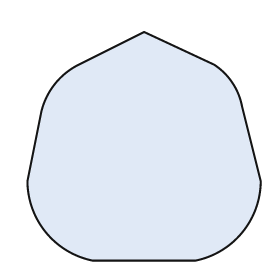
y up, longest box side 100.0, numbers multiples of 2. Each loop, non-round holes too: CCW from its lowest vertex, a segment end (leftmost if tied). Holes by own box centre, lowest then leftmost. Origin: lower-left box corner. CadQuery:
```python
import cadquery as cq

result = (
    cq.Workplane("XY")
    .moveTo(28.0, 0.0)
    .lineTo(72.0, 0.0)
    .threePointArc((92.0, 12.0), (100.0, 34.0))
    .lineTo(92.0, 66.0)
    .threePointArc((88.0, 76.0), (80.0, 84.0))
    .lineTo(50.0, 98.0)
    .lineTo(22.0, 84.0)
    .threePointArc((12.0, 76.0), (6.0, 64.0))
    .lineTo(0.0, 34.0)
    .threePointArc((8.0, 12.0), (28.0, 0.0))
    .close()
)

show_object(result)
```